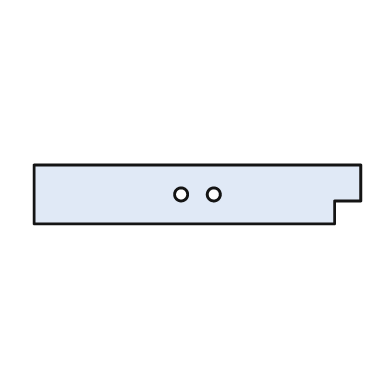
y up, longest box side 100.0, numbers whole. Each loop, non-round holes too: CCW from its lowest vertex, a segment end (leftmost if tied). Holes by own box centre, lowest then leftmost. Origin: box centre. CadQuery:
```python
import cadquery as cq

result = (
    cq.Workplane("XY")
    .moveTo(-50.0, -9.0)
    .lineTo(42.0, -9.0)
    .lineTo(42.0, -2.0)
    .lineTo(50.0, -2.0)
    .lineTo(50.0, 9.0)
    .lineTo(-50.0, 9.0)
    .close()
    .moveTo(-5.0, 0.0)
    .circle(2.0)
    .moveTo(5.0, 0.0)
    .circle(2.0)
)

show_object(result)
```